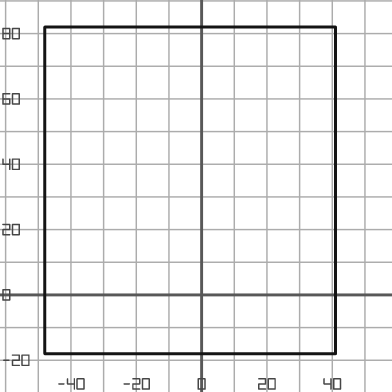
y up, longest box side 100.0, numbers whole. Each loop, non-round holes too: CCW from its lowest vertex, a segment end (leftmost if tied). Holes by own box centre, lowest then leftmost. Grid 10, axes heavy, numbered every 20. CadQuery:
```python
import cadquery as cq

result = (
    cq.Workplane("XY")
    .moveTo(-48.0, -18.0)
    .lineTo(41.0, -18.0)
    .lineTo(41.0, 82.0)
    .lineTo(-48.0, 82.0)
    .close()
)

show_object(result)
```